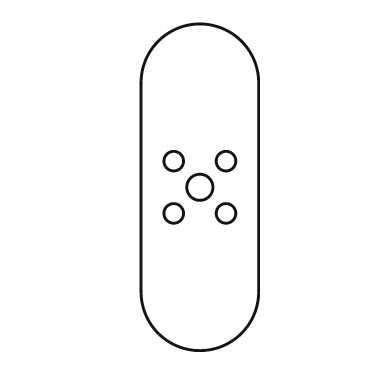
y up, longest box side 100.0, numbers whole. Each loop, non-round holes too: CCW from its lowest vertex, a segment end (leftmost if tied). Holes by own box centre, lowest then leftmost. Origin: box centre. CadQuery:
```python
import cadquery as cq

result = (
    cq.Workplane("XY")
    .moveTo(-18.0, -32.0)
    .threePointArc((0.0, -50.0), (18.0, -32.0))
    .lineTo(18.0, 32.0)
    .threePointArc((0.0, 50.0), (-18.0, 32.0))
    .close()
    .moveTo(-8.0, -8.0)
    .circle(3.0)
    .moveTo(8.0, -8.0)
    .circle(3.0)
    .moveTo(0.0, 0.0)
    .circle(4.0)
    .moveTo(-8.0, 8.0)
    .circle(3.0)
    .moveTo(8.0, 8.0)
    .circle(3.0)
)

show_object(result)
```